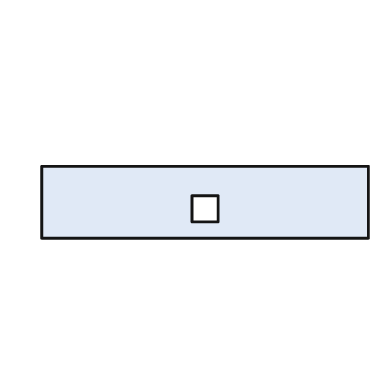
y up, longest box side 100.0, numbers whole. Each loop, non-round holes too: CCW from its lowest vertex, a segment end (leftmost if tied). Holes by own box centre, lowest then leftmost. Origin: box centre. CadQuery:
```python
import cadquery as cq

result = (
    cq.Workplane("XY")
    .moveTo(-50.0, -11.0)
    .lineTo(50.0, -11.0)
    .lineTo(50.0, 11.0)
    .lineTo(-50.0, 11.0)
    .close()
    .moveTo(-4.0, -6.0)
    .lineTo(4.0, -6.0)
    .lineTo(4.0, 2.0)
    .lineTo(-4.0, 2.0)
    .close()
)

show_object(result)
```